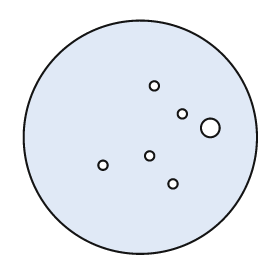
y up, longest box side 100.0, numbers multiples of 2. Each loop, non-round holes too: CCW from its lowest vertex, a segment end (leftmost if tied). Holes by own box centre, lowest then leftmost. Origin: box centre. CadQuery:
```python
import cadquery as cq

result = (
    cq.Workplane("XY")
    .moveTo(0.0, 0.0)
    .circle(50.0)
    .moveTo(14.0, -20.0)
    .circle(2.0)
    .moveTo(-16.0, -12.0)
    .circle(2.0)
    .moveTo(4.0, -8.0)
    .circle(2.0)
    .moveTo(30.0, 4.0)
    .circle(4.0)
    .moveTo(18.0, 10.0)
    .circle(2.0)
    .moveTo(6.0, 22.0)
    .circle(2.0)
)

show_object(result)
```